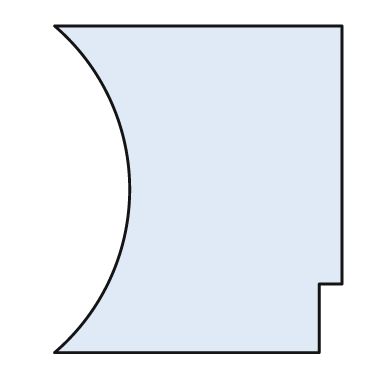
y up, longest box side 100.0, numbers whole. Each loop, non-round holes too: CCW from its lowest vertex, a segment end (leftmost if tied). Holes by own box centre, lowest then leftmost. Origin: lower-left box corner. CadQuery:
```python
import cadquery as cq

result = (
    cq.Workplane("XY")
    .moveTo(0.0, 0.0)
    .lineTo(81.0, 0.0)
    .lineTo(81.0, 21.0)
    .lineTo(88.0, 21.0)
    .lineTo(88.0, 100.0)
    .lineTo(0.0, 100.0)
    .threePointArc((23.0, 50.0), (0.0, 0.0))
    .close()
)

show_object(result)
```